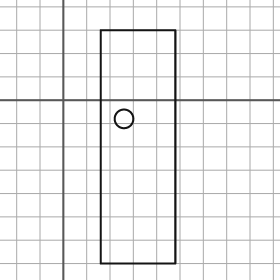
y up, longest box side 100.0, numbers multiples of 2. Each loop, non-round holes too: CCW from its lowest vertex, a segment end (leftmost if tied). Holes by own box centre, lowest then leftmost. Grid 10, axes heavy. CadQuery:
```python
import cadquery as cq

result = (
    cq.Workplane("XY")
    .moveTo(16.0, -70.0)
    .lineTo(48.0, -70.0)
    .lineTo(48.0, 30.0)
    .lineTo(16.0, 30.0)
    .close()
    .moveTo(26.0, -8.0)
    .circle(4.0)
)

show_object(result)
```